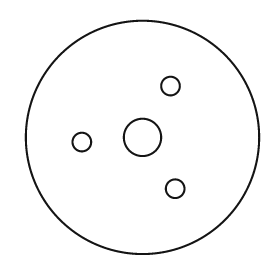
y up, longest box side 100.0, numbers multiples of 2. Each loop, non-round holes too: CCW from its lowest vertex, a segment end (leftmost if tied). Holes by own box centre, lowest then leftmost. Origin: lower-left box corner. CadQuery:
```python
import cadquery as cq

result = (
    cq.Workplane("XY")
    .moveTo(50.0, 50.0)
    .circle(50.0)
    .moveTo(64.0, 28.0)
    .circle(4.0)
    .moveTo(24.0, 48.0)
    .circle(4.0)
    .moveTo(50.0, 50.0)
    .circle(8.0)
    .moveTo(62.0, 72.0)
    .circle(4.0)
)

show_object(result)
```